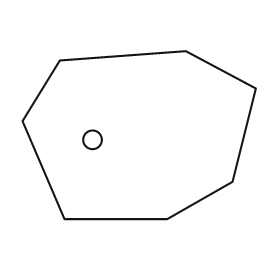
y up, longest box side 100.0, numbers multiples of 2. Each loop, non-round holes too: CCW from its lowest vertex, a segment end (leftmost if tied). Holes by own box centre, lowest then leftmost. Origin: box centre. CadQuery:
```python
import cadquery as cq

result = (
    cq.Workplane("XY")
    .moveTo(-32.0, -36.0)
    .lineTo(12.0, -36.0)
    .lineTo(40.0, -20.0)
    .lineTo(50.0, 20.0)
    .lineTo(20.0, 36.0)
    .lineTo(-34.0, 32.0)
    .lineTo(-50.0, 6.0)
    .close()
    .moveTo(-20.0, -2.0)
    .circle(4.0)
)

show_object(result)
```